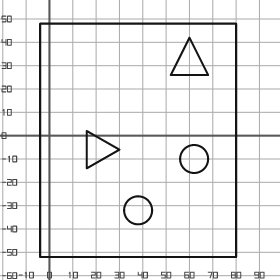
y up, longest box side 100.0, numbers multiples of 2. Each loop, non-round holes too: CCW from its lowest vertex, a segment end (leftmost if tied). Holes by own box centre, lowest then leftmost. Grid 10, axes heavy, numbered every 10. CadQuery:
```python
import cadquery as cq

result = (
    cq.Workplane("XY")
    .moveTo(-4.0, -52.0)
    .lineTo(80.0, -52.0)
    .lineTo(80.0, 48.0)
    .lineTo(-4.0, 48.0)
    .close()
    .moveTo(38.0, -32.0)
    .circle(6.0)
    .moveTo(62.0, -10.0)
    .circle(6.0)
    .moveTo(16.0, -14.0)
    .lineTo(30.0, -6.0)
    .lineTo(16.0, 2.0)
    .close()
    .moveTo(52.0, 26.0)
    .lineTo(68.0, 26.0)
    .lineTo(60.0, 42.0)
    .close()
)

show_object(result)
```